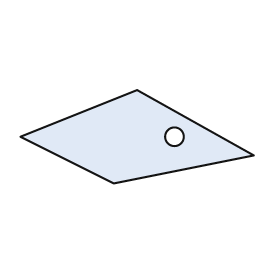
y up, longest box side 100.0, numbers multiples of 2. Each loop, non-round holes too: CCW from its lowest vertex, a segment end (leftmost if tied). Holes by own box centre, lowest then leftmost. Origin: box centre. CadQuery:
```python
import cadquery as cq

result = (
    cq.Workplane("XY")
    .moveTo(-10.0, -20.0)
    .lineTo(50.0, -8.0)
    .lineTo(0.0, 20.0)
    .lineTo(-50.0, 0.0)
    .close()
    .moveTo(16.0, 0.0)
    .circle(4.0)
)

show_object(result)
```